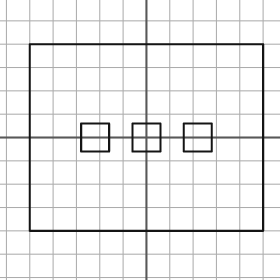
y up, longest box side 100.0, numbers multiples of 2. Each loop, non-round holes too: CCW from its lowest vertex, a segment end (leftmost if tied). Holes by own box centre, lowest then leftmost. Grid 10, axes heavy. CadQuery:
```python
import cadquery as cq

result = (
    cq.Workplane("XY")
    .moveTo(-50.0, -40.0)
    .lineTo(50.0, -40.0)
    .lineTo(50.0, 40.0)
    .lineTo(-50.0, 40.0)
    .close()
    .moveTo(-28.0, -6.0)
    .lineTo(-16.0, -6.0)
    .lineTo(-16.0, 6.0)
    .lineTo(-28.0, 6.0)
    .close()
    .moveTo(-6.0, -6.0)
    .lineTo(6.0, -6.0)
    .lineTo(6.0, 6.0)
    .lineTo(-6.0, 6.0)
    .close()
    .moveTo(16.0, -6.0)
    .lineTo(28.0, -6.0)
    .lineTo(28.0, 6.0)
    .lineTo(16.0, 6.0)
    .close()
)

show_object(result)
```